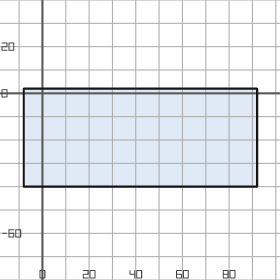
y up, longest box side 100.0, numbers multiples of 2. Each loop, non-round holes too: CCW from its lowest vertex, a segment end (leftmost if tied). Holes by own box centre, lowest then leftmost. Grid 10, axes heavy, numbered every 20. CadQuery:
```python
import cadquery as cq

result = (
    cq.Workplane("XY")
    .moveTo(-8.0, -40.0)
    .lineTo(92.0, -40.0)
    .lineTo(92.0, 2.0)
    .lineTo(-8.0, 2.0)
    .close()
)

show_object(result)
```